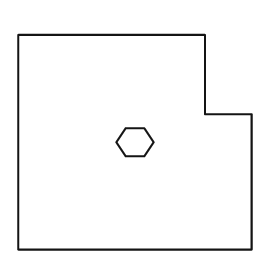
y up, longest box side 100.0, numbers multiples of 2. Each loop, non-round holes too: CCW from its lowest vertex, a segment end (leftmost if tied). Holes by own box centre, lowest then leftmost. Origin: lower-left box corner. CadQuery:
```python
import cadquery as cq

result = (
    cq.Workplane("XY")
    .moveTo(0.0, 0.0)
    .lineTo(100.0, 0.0)
    .lineTo(100.0, 58.0)
    .lineTo(80.0, 58.0)
    .lineTo(80.0, 92.0)
    .lineTo(0.0, 92.0)
    .close()
    .moveTo(46.0, 40.0)
    .lineTo(54.0, 40.0)
    .lineTo(58.0, 46.0)
    .lineTo(54.0, 52.0)
    .lineTo(46.0, 52.0)
    .lineTo(42.0, 46.0)
    .close()
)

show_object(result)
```